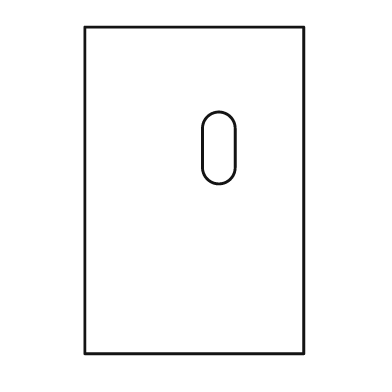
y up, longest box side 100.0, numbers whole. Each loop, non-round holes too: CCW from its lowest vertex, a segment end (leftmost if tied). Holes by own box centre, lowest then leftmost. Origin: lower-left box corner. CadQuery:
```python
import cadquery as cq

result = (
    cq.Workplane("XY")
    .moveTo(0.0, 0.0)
    .lineTo(67.0, 0.0)
    .lineTo(67.0, 100.0)
    .lineTo(0.0, 100.0)
    .close()
    .moveTo(36.0, 57.0)
    .threePointArc((41.0, 52.0), (46.0, 57.0))
    .lineTo(46.0, 69.0)
    .threePointArc((41.0, 74.0), (36.0, 69.0))
    .close()
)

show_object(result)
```